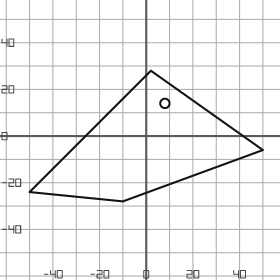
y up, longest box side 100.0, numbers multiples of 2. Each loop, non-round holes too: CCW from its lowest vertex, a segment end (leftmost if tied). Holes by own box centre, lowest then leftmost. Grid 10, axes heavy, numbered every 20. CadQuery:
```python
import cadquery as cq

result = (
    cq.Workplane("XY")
    .moveTo(-10.0, -28.0)
    .lineTo(50.0, -6.0)
    .lineTo(2.0, 28.0)
    .lineTo(-50.0, -24.0)
    .close()
    .moveTo(8.0, 14.0)
    .circle(2.0)
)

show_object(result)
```